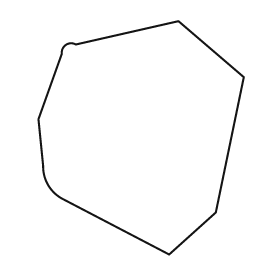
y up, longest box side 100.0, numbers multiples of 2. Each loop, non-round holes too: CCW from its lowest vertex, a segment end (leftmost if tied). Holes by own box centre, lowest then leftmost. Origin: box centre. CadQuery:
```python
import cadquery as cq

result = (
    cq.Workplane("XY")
    .moveTo(12.0, -50.0)
    .lineTo(32.0, -32.0)
    .lineTo(44.0, 26.0)
    .lineTo(16.0, 50.0)
    .lineTo(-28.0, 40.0)
    .threePointArc((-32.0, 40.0), (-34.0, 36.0))
    .lineTo(-44.0, 8.0)
    .lineTo(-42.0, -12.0)
    .threePointArc((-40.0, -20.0), (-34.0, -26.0))
    .close()
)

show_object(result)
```